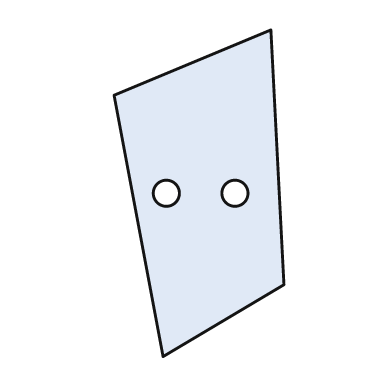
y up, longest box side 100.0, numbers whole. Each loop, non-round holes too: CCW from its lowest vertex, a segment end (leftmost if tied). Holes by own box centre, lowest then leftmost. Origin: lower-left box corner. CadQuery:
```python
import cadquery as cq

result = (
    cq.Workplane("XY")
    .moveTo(15.0, 0.0)
    .lineTo(52.0, 22.0)
    .lineTo(48.0, 100.0)
    .lineTo(0.0, 80.0)
    .close()
    .moveTo(16.0, 50.0)
    .circle(4.0)
    .moveTo(37.0, 50.0)
    .circle(4.0)
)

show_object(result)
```